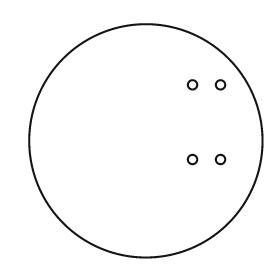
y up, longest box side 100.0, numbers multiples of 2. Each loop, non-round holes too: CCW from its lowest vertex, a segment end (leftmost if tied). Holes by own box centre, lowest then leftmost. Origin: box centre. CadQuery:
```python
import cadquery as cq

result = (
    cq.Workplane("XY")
    .moveTo(0.0, 0.0)
    .circle(50.0)
    .moveTo(20.0, -8.0)
    .circle(2.0)
    .moveTo(32.0, -8.0)
    .circle(2.0)
    .moveTo(20.0, 24.0)
    .circle(2.0)
    .moveTo(32.0, 24.0)
    .circle(2.0)
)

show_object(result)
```